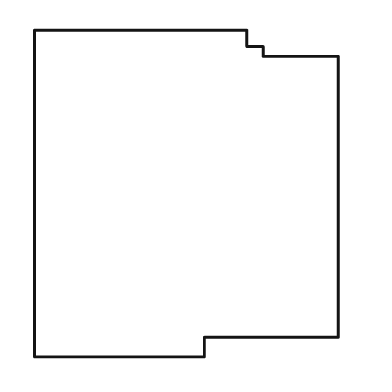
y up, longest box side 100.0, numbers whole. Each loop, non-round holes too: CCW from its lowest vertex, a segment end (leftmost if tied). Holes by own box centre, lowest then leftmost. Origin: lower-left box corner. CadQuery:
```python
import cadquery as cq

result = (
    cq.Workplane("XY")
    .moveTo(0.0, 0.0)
    .lineTo(52.0, 0.0)
    .lineTo(52.0, 6.0)
    .lineTo(93.0, 6.0)
    .lineTo(93.0, 92.0)
    .lineTo(70.0, 92.0)
    .lineTo(70.0, 95.0)
    .lineTo(65.0, 95.0)
    .lineTo(65.0, 100.0)
    .lineTo(0.0, 100.0)
    .close()
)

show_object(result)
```